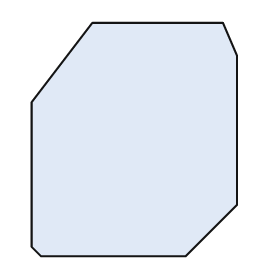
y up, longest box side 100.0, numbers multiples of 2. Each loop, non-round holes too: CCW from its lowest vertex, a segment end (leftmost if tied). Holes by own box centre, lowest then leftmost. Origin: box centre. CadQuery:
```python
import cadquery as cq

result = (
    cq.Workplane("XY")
    .moveTo(-40.0, -50.0)
    .lineTo(22.0, -50.0)
    .lineTo(44.0, -28.0)
    .lineTo(44.0, 36.0)
    .lineTo(38.0, 50.0)
    .lineTo(-18.0, 50.0)
    .lineTo(-44.0, 16.0)
    .lineTo(-44.0, -46.0)
    .close()
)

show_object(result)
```